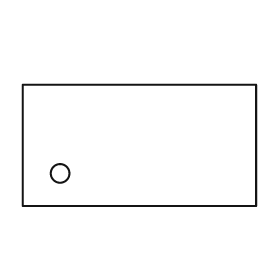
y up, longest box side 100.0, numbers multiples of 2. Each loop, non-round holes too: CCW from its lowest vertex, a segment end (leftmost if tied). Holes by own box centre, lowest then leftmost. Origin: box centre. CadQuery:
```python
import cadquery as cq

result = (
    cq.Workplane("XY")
    .moveTo(-50.0, -26.0)
    .lineTo(50.0, -26.0)
    .lineTo(50.0, 26.0)
    .lineTo(-50.0, 26.0)
    .close()
    .moveTo(-34.0, -12.0)
    .circle(4.0)
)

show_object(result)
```